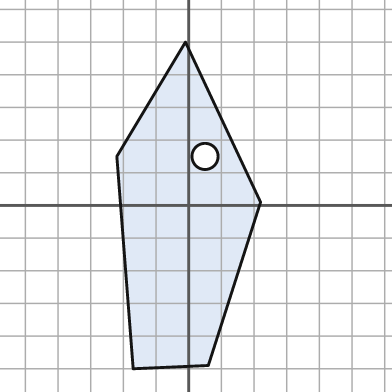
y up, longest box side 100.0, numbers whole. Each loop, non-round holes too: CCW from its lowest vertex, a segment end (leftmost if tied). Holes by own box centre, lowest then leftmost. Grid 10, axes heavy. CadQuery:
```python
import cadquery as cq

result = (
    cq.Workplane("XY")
    .moveTo(-17.0, -50.0)
    .lineTo(6.0, -49.0)
    .lineTo(22.0, 1.0)
    .lineTo(-1.0, 50.0)
    .lineTo(-22.0, 15.0)
    .close()
    .moveTo(5.0, 15.0)
    .circle(4.0)
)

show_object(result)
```